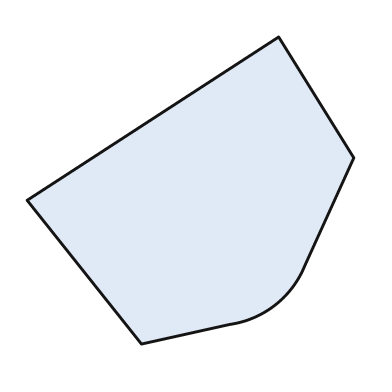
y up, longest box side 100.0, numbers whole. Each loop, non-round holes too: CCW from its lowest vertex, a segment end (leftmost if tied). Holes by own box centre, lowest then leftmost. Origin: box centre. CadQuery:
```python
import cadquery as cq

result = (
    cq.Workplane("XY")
    .moveTo(-15.0, -47.0)
    .lineTo(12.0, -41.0)
    .threePointArc((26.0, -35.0), (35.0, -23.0))
    .lineTo(50.0, 10.0)
    .lineTo(27.0, 47.0)
    .lineTo(-50.0, -3.0)
    .close()
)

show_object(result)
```